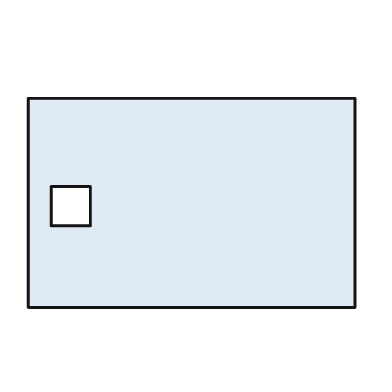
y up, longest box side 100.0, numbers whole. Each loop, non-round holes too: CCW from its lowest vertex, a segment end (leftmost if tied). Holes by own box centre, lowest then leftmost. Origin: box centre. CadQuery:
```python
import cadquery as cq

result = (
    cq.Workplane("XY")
    .moveTo(-50.0, -32.0)
    .lineTo(50.0, -32.0)
    .lineTo(50.0, 32.0)
    .lineTo(-50.0, 32.0)
    .close()
    .moveTo(-43.0, -7.0)
    .lineTo(-31.0, -7.0)
    .lineTo(-31.0, 5.0)
    .lineTo(-43.0, 5.0)
    .close()
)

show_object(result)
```